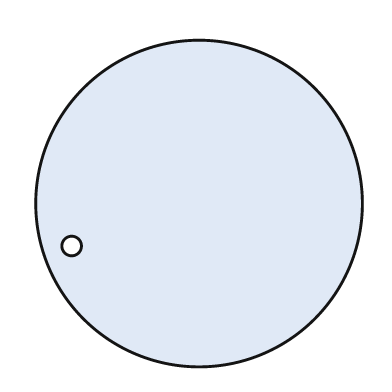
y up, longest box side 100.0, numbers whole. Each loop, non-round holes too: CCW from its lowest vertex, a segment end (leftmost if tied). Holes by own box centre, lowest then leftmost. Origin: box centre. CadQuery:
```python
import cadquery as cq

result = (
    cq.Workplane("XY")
    .moveTo(0.0, 0.0)
    .circle(50.0)
    .moveTo(-39.0, -13.0)
    .circle(3.0)
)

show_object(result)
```